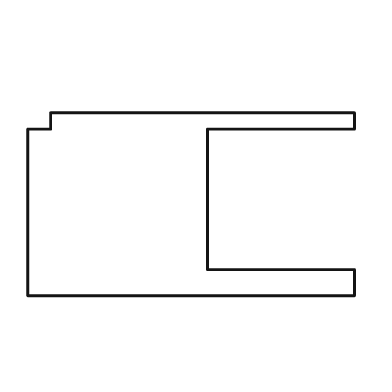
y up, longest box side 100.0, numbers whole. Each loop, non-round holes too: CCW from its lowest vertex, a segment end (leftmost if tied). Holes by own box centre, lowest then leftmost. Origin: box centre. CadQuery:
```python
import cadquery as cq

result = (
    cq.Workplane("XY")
    .moveTo(-50.0, -28.0)
    .lineTo(50.0, -28.0)
    .lineTo(50.0, -20.0)
    .lineTo(5.0, -20.0)
    .lineTo(5.0, 23.0)
    .lineTo(50.0, 23.0)
    .lineTo(50.0, 28.0)
    .lineTo(-43.0, 28.0)
    .lineTo(-43.0, 23.0)
    .lineTo(-50.0, 23.0)
    .close()
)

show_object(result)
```